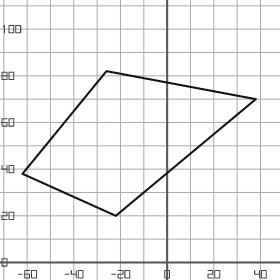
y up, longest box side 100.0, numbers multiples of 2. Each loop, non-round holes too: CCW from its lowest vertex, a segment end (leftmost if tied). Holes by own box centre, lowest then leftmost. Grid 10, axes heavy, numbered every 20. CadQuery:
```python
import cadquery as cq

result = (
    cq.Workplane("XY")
    .moveTo(-22.0, 20.0)
    .lineTo(38.0, 70.0)
    .lineTo(-26.0, 82.0)
    .lineTo(-62.0, 38.0)
    .close()
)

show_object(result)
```